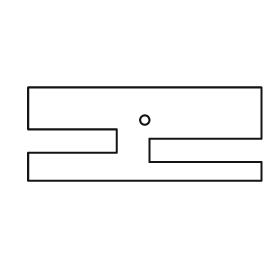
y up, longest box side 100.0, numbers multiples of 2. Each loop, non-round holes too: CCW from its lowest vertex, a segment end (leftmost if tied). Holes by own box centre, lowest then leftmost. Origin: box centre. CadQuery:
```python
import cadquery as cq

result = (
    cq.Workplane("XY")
    .moveTo(-50.0, -20.0)
    .lineTo(50.0, -20.0)
    .lineTo(50.0, -12.0)
    .lineTo(2.0, -12.0)
    .lineTo(2.0, -2.0)
    .lineTo(50.0, -2.0)
    .lineTo(50.0, 20.0)
    .lineTo(-50.0, 20.0)
    .lineTo(-50.0, 2.0)
    .lineTo(-12.0, 2.0)
    .lineTo(-12.0, -8.0)
    .lineTo(-50.0, -8.0)
    .close()
    .moveTo(0.0, 6.0)
    .circle(2.0)
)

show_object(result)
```